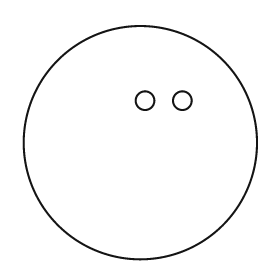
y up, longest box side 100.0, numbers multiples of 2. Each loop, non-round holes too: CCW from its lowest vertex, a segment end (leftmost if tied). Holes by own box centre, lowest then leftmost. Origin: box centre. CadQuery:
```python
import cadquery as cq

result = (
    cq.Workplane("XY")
    .moveTo(0.0, 0.0)
    .circle(50.0)
    .moveTo(2.0, 18.0)
    .circle(4.0)
    .moveTo(18.0, 18.0)
    .circle(4.0)
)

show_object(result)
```